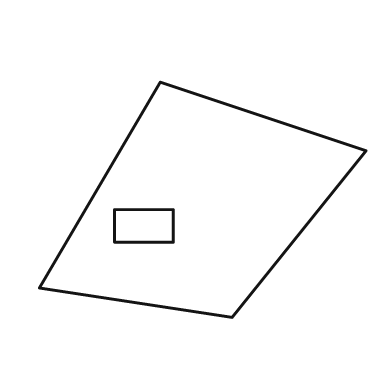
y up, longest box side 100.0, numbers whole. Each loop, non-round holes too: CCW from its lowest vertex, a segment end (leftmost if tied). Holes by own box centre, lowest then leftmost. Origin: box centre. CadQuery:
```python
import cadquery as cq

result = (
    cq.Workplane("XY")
    .moveTo(9.0, -36.0)
    .lineTo(50.0, 15.0)
    .lineTo(-13.0, 36.0)
    .lineTo(-50.0, -27.0)
    .close()
    .moveTo(-27.0, -13.0)
    .lineTo(-9.0, -13.0)
    .lineTo(-9.0, -3.0)
    .lineTo(-27.0, -3.0)
    .close()
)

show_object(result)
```